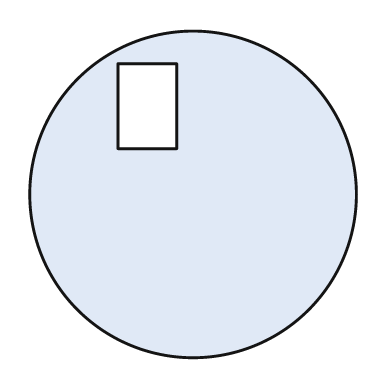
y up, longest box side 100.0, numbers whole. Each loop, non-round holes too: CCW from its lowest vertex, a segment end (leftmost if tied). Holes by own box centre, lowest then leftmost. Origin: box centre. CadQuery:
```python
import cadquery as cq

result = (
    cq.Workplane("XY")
    .moveTo(0.0, 0.0)
    .circle(50.0)
    .moveTo(-23.0, 14.0)
    .lineTo(-5.0, 14.0)
    .lineTo(-5.0, 40.0)
    .lineTo(-23.0, 40.0)
    .close()
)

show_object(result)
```